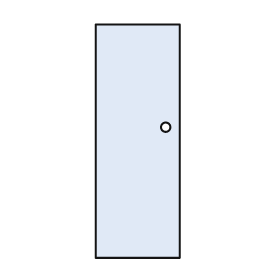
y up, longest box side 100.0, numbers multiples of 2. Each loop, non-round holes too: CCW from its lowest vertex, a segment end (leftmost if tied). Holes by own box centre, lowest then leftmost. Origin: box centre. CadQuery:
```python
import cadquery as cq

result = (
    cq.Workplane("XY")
    .moveTo(-18.0, -50.0)
    .lineTo(18.0, -50.0)
    .lineTo(18.0, 50.0)
    .lineTo(-18.0, 50.0)
    .close()
    .moveTo(12.0, 6.0)
    .circle(2.0)
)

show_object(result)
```